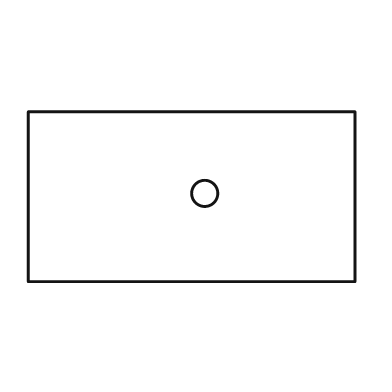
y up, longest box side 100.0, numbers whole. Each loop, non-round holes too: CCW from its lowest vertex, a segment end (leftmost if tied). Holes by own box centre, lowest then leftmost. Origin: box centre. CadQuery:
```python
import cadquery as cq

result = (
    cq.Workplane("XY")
    .moveTo(-50.0, -26.0)
    .lineTo(50.0, -26.0)
    .lineTo(50.0, 26.0)
    .lineTo(-50.0, 26.0)
    .close()
    .moveTo(4.0, 1.0)
    .circle(4.0)
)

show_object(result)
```